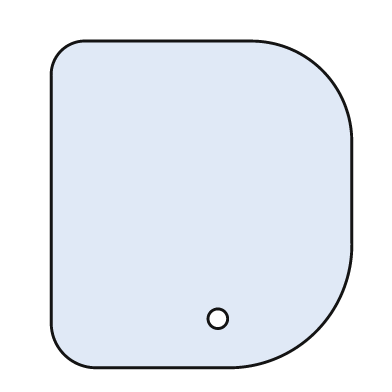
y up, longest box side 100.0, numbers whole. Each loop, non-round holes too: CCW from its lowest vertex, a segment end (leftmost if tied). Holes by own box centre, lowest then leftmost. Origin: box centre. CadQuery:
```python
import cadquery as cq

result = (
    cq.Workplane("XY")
    .moveTo(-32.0, -50.0)
    .lineTo(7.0, -50.0)
    .threePointArc((35.0, -39.0), (46.0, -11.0))
    .lineTo(46.0, 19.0)
    .threePointArc((37.0, 41.0), (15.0, 50.0))
    .lineTo(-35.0, 50.0)
    .threePointArc((-43.0, 47.0), (-46.0, 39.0))
    .lineTo(-46.0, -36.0)
    .threePointArc((-42.0, -46.0), (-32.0, -50.0))
    .close()
    .moveTo(5.0, -35.0)
    .circle(3.0)
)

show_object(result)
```